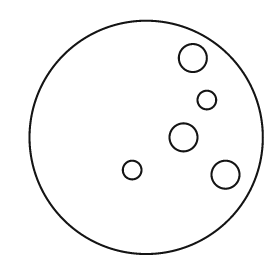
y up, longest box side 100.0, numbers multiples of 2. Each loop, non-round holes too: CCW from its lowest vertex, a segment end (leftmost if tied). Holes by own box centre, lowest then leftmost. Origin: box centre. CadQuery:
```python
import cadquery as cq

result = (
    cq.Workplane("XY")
    .moveTo(0.0, 0.0)
    .circle(50.0)
    .moveTo(34.0, -16.0)
    .circle(6.0)
    .moveTo(-6.0, -14.0)
    .circle(4.0)
    .moveTo(16.0, 0.0)
    .circle(6.0)
    .moveTo(26.0, 16.0)
    .circle(4.0)
    .moveTo(20.0, 34.0)
    .circle(6.0)
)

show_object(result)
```